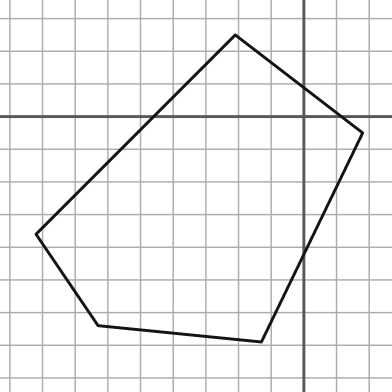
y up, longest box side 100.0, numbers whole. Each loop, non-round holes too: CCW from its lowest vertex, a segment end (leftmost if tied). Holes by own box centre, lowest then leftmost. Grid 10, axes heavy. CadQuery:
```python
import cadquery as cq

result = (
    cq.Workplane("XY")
    .moveTo(-13.0, -69.0)
    .lineTo(18.0, -5.0)
    .lineTo(-21.0, 25.0)
    .lineTo(-82.0, -36.0)
    .lineTo(-63.0, -64.0)
    .close()
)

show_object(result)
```